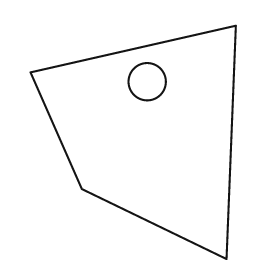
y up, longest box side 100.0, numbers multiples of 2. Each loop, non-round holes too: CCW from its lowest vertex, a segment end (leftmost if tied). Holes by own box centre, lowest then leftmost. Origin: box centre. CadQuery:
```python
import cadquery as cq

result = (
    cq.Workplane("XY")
    .moveTo(40.0, -50.0)
    .lineTo(44.0, 50.0)
    .lineTo(-44.0, 30.0)
    .lineTo(-22.0, -20.0)
    .close()
    .moveTo(6.0, 26.0)
    .circle(8.0)
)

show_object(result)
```